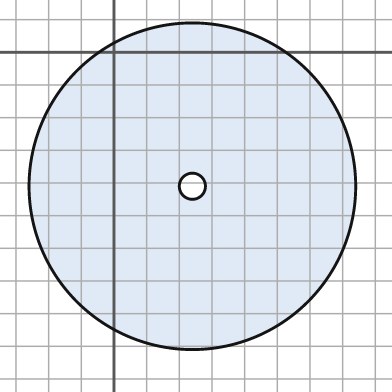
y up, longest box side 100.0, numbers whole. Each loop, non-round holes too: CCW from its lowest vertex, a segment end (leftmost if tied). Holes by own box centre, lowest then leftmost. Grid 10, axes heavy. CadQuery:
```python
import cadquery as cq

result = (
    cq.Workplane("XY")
    .moveTo(24.0, -41.0)
    .circle(50.0)
    .moveTo(24.0, -41.0)
    .circle(4.0)
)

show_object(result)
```